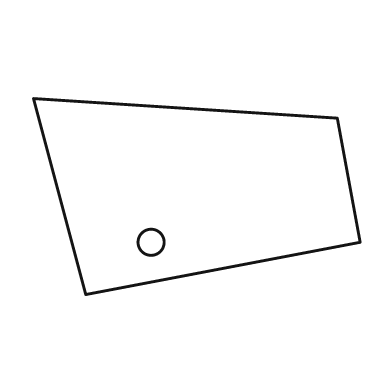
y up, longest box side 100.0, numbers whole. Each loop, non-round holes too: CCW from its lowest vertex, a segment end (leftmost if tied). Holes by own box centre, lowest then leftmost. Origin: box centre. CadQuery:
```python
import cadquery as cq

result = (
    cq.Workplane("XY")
    .moveTo(-34.0, -30.0)
    .lineTo(50.0, -14.0)
    .lineTo(43.0, 24.0)
    .lineTo(-50.0, 30.0)
    .close()
    .moveTo(-14.0, -14.0)
    .circle(4.0)
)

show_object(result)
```